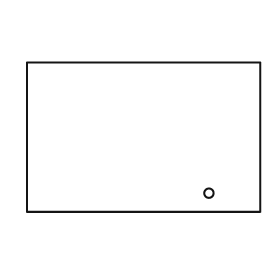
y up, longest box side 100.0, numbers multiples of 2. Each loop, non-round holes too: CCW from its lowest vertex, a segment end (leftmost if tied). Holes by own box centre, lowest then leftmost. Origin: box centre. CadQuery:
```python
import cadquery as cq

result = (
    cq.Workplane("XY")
    .moveTo(-50.0, -32.0)
    .lineTo(50.0, -32.0)
    .lineTo(50.0, 32.0)
    .lineTo(-50.0, 32.0)
    .close()
    .moveTo(28.0, -24.0)
    .circle(2.0)
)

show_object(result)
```